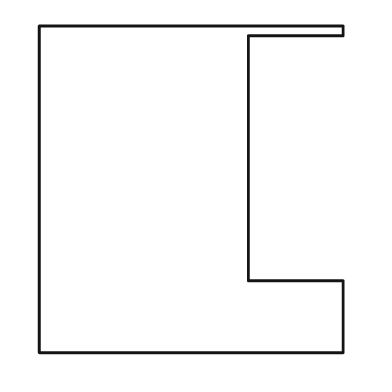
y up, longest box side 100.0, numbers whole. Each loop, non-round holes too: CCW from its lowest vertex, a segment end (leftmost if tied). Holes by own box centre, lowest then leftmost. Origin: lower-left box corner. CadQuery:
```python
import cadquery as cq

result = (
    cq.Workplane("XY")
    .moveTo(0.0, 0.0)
    .lineTo(93.0, 0.0)
    .lineTo(93.0, 22.0)
    .lineTo(64.0, 22.0)
    .lineTo(64.0, 97.0)
    .lineTo(93.0, 97.0)
    .lineTo(93.0, 100.0)
    .lineTo(0.0, 100.0)
    .close()
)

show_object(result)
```